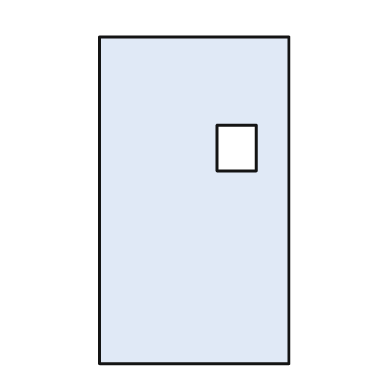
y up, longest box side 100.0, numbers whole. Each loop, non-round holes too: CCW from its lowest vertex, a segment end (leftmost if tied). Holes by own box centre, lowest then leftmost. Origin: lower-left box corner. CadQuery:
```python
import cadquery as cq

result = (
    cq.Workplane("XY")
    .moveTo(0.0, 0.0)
    .lineTo(58.0, 0.0)
    .lineTo(58.0, 100.0)
    .lineTo(0.0, 100.0)
    .close()
    .moveTo(36.0, 59.0)
    .lineTo(48.0, 59.0)
    .lineTo(48.0, 73.0)
    .lineTo(36.0, 73.0)
    .close()
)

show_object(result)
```